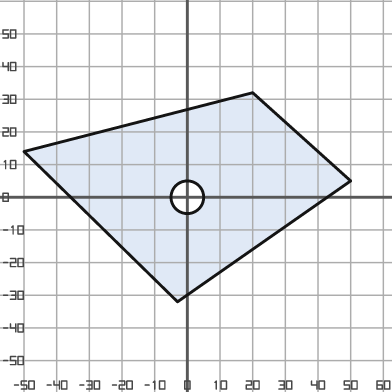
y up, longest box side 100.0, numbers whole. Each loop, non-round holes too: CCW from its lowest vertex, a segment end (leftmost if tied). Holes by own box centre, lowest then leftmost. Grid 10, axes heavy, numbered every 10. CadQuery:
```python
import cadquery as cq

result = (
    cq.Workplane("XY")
    .moveTo(-3.0, -32.0)
    .lineTo(50.0, 5.0)
    .lineTo(20.0, 32.0)
    .lineTo(-50.0, 14.0)
    .close()
    .moveTo(0.0, 0.0)
    .circle(5.0)
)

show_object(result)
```